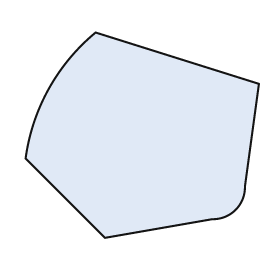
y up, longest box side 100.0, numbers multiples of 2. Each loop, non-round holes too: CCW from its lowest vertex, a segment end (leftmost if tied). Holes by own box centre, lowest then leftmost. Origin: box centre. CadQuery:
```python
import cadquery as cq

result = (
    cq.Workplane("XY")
    .moveTo(-16.0, -44.0)
    .lineTo(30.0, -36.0)
    .threePointArc((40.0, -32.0), (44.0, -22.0))
    .lineTo(50.0, 22.0)
    .lineTo(-20.0, 44.0)
    .threePointArc((-40.0, 20.0), (-50.0, -10.0))
    .close()
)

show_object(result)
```